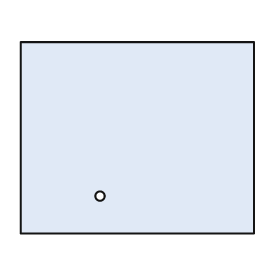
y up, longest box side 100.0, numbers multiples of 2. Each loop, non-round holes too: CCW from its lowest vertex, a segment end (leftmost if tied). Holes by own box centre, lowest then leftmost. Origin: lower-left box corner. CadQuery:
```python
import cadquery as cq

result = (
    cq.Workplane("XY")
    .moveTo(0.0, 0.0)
    .lineTo(100.0, 0.0)
    .lineTo(100.0, 82.0)
    .lineTo(0.0, 82.0)
    .close()
    .moveTo(34.0, 16.0)
    .circle(2.0)
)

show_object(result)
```